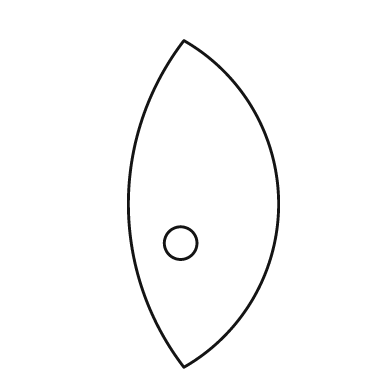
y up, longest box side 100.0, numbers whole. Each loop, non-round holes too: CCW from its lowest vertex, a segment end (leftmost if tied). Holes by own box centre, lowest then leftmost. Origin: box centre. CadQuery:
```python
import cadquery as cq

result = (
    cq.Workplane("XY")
    .moveTo(-6.0, -50.0)
    .threePointArc((23.0, 0.0), (-6.0, 50.0))
    .threePointArc((-23.0, 0.0), (-6.0, -50.0))
    .close()
    .moveTo(-7.0, -12.0)
    .circle(5.0)
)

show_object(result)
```